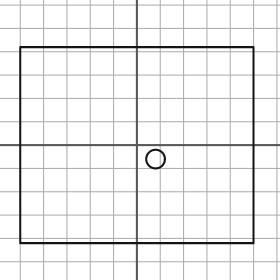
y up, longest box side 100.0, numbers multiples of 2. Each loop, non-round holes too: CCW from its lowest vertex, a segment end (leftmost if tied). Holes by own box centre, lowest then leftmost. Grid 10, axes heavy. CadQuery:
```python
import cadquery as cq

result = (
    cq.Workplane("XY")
    .moveTo(-50.0, -42.0)
    .lineTo(50.0, -42.0)
    .lineTo(50.0, 42.0)
    .lineTo(-50.0, 42.0)
    .close()
    .moveTo(8.0, -6.0)
    .circle(4.0)
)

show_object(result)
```